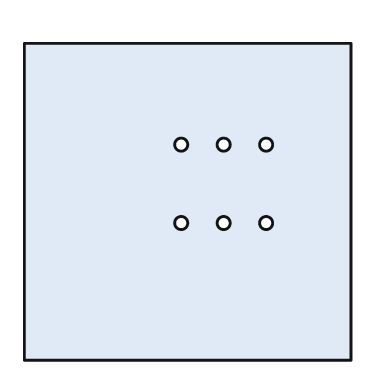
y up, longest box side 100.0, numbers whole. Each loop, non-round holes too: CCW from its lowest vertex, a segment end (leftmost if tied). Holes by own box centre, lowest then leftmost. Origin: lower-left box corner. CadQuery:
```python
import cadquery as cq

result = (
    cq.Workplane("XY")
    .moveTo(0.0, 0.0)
    .lineTo(100.0, 0.0)
    .lineTo(100.0, 97.0)
    .lineTo(0.0, 97.0)
    .close()
    .moveTo(48.0, 42.0)
    .circle(2.0)
    .moveTo(61.0, 42.0)
    .circle(2.0)
    .moveTo(74.0, 42.0)
    .circle(2.0)
    .moveTo(48.0, 66.0)
    .circle(2.0)
    .moveTo(61.0, 66.0)
    .circle(2.0)
    .moveTo(74.0, 66.0)
    .circle(2.0)
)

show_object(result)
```